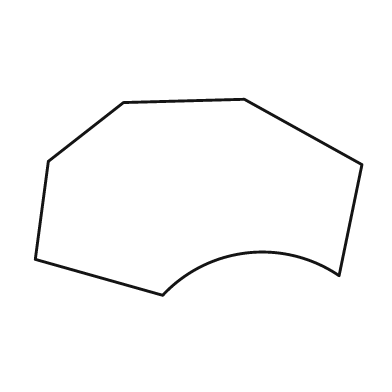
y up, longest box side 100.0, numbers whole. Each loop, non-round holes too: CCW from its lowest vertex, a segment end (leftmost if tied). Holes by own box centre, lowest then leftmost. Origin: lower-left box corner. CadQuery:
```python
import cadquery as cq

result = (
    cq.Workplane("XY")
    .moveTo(39.0, 0.0)
    .threePointArc((65.0, 13.0), (93.0, 6.0))
    .lineTo(100.0, 40.0)
    .lineTo(64.0, 60.0)
    .lineTo(27.0, 59.0)
    .lineTo(4.0, 41.0)
    .lineTo(0.0, 11.0)
    .close()
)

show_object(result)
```